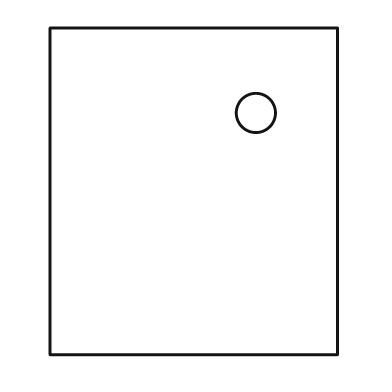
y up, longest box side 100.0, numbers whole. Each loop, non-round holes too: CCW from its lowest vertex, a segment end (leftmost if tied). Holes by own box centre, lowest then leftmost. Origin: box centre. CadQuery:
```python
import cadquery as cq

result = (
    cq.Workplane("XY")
    .moveTo(-44.0, -50.0)
    .lineTo(44.0, -50.0)
    .lineTo(44.0, 50.0)
    .lineTo(-44.0, 50.0)
    .close()
    .moveTo(19.0, 24.0)
    .circle(6.0)
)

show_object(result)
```